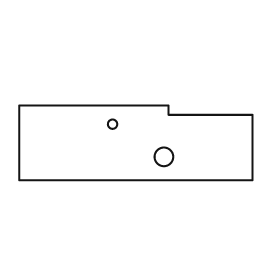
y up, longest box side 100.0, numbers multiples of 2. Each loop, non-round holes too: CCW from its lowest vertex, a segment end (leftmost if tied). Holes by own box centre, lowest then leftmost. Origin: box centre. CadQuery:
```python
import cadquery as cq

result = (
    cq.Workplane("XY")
    .moveTo(-50.0, -16.0)
    .lineTo(50.0, -16.0)
    .lineTo(50.0, 12.0)
    .lineTo(14.0, 12.0)
    .lineTo(14.0, 16.0)
    .lineTo(-50.0, 16.0)
    .close()
    .moveTo(12.0, -6.0)
    .circle(4.0)
    .moveTo(-10.0, 8.0)
    .circle(2.0)
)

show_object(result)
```